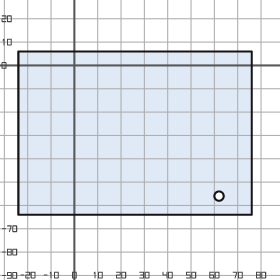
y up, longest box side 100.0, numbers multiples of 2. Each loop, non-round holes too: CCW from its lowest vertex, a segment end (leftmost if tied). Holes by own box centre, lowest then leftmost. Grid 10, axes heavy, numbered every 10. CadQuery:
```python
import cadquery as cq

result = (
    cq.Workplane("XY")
    .moveTo(-24.0, -64.0)
    .lineTo(76.0, -64.0)
    .lineTo(76.0, 6.0)
    .lineTo(-24.0, 6.0)
    .close()
    .moveTo(62.0, -56.0)
    .circle(2.0)
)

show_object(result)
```